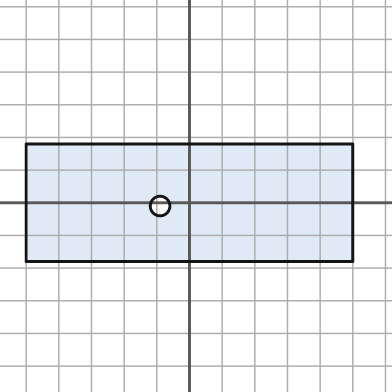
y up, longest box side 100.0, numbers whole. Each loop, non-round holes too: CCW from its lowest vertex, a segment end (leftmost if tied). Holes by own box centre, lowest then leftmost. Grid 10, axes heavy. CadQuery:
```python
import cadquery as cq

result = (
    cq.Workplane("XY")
    .moveTo(-50.0, -18.0)
    .lineTo(50.0, -18.0)
    .lineTo(50.0, 18.0)
    .lineTo(-50.0, 18.0)
    .close()
    .moveTo(-9.0, -1.0)
    .circle(3.0)
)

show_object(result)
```